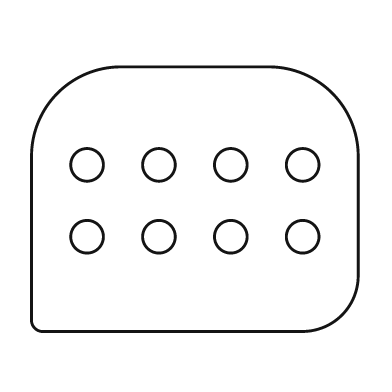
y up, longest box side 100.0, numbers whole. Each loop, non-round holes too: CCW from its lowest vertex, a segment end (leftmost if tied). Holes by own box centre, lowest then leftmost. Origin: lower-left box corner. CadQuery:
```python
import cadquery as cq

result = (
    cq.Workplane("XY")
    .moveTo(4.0, 0.0)
    .lineTo(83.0, 0.0)
    .threePointArc((95.0, 5.0), (100.0, 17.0))
    .lineTo(100.0, 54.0)
    .threePointArc((92.0, 73.0), (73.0, 81.0))
    .lineTo(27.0, 81.0)
    .threePointArc((8.0, 73.0), (0.0, 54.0))
    .lineTo(0.0, 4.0)
    .threePointArc((1.0, 1.0), (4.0, 0.0))
    .close()
    .moveTo(17.0, 29.0)
    .circle(5.0)
    .moveTo(39.0, 29.0)
    .circle(5.0)
    .moveTo(61.0, 29.0)
    .circle(5.0)
    .moveTo(83.0, 29.0)
    .circle(5.0)
    .moveTo(17.0, 51.0)
    .circle(5.0)
    .moveTo(39.0, 51.0)
    .circle(5.0)
    .moveTo(61.0, 51.0)
    .circle(5.0)
    .moveTo(83.0, 51.0)
    .circle(5.0)
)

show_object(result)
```